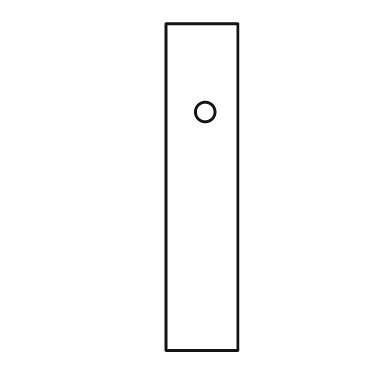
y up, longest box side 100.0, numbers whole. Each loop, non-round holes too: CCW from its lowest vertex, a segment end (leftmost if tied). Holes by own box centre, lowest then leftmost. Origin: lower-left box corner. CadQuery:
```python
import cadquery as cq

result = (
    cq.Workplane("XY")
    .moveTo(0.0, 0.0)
    .lineTo(22.0, 0.0)
    .lineTo(22.0, 100.0)
    .lineTo(0.0, 100.0)
    .close()
    .moveTo(12.0, 73.0)
    .circle(3.0)
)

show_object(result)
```